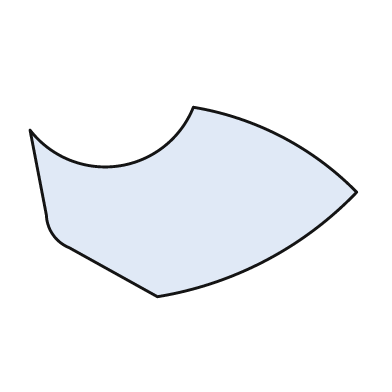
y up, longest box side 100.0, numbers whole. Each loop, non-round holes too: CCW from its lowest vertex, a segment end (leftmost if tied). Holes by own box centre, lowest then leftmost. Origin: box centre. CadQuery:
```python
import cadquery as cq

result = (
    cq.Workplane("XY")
    .moveTo(-11.0, -29.0)
    .threePointArc((22.0, -18.0), (50.0, 3.0))
    .threePointArc((27.0, 20.0), (0.0, 29.0))
    .threePointArc((-23.0, 11.0), (-50.0, 22.0))
    .lineTo(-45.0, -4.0)
    .threePointArc((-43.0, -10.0), (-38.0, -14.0))
    .close()
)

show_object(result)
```